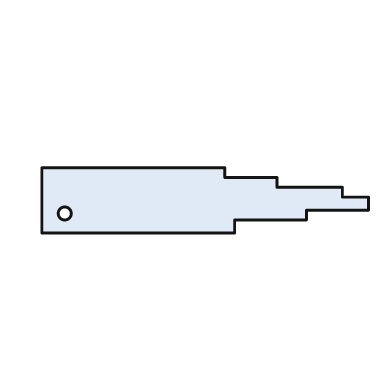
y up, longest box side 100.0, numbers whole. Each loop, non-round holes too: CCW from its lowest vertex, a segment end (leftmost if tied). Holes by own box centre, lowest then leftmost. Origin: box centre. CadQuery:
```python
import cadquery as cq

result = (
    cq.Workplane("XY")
    .moveTo(-50.0, -10.0)
    .lineTo(9.0, -10.0)
    .lineTo(9.0, -6.0)
    .lineTo(31.0, -6.0)
    .lineTo(31.0, -3.0)
    .lineTo(50.0, -3.0)
    .lineTo(50.0, 1.0)
    .lineTo(42.0, 1.0)
    .lineTo(42.0, 4.0)
    .lineTo(22.0, 4.0)
    .lineTo(22.0, 7.0)
    .lineTo(6.0, 7.0)
    .lineTo(6.0, 10.0)
    .lineTo(-50.0, 10.0)
    .close()
    .moveTo(-43.0, -4.0)
    .circle(2.0)
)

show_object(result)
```